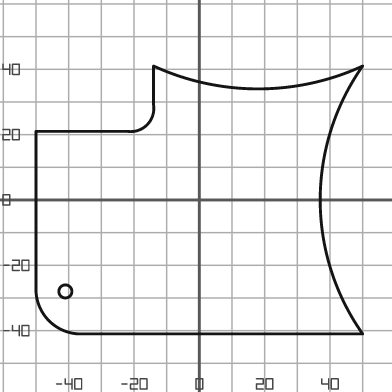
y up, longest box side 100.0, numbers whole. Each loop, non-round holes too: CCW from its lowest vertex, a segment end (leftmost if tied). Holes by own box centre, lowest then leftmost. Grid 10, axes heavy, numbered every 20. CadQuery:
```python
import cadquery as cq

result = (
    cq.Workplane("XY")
    .moveTo(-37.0, -41.0)
    .lineTo(50.0, -41.0)
    .threePointArc((37.0, 0.0), (50.0, 41.0))
    .threePointArc((18.0, 34.0), (-14.0, 41.0))
    .lineTo(-14.0, 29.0)
    .threePointArc((-16.0, 23.0), (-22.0, 21.0))
    .lineTo(-50.0, 21.0)
    .lineTo(-50.0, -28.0)
    .threePointArc((-46.0, -37.0), (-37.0, -41.0))
    .close()
    .moveTo(-41.0, -28.0)
    .circle(2.0)
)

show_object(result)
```